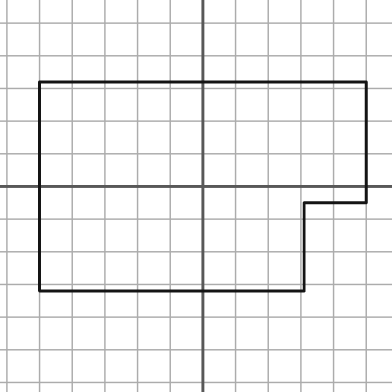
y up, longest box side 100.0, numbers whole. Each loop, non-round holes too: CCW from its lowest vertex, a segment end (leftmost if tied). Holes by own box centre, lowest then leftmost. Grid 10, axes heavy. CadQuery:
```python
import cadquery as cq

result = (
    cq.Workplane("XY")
    .moveTo(-50.0, -32.0)
    .lineTo(31.0, -32.0)
    .lineTo(31.0, -5.0)
    .lineTo(50.0, -5.0)
    .lineTo(50.0, 32.0)
    .lineTo(-50.0, 32.0)
    .close()
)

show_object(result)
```